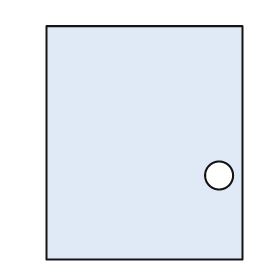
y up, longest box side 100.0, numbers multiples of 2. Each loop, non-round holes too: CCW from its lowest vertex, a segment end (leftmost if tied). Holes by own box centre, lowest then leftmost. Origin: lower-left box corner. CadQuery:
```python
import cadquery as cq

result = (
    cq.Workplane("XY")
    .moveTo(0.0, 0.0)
    .lineTo(84.0, 0.0)
    .lineTo(84.0, 100.0)
    .lineTo(0.0, 100.0)
    .close()
    .moveTo(74.0, 36.0)
    .circle(6.0)
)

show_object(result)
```